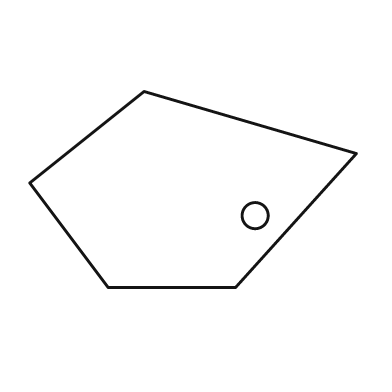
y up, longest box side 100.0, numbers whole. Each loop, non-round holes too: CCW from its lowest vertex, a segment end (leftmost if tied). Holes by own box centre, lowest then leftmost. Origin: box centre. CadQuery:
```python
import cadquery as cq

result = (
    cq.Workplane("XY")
    .moveTo(-26.0, -30.0)
    .lineTo(13.0, -30.0)
    .lineTo(50.0, 11.0)
    .lineTo(-15.0, 30.0)
    .lineTo(-50.0, 2.0)
    .close()
    .moveTo(19.0, -8.0)
    .circle(4.0)
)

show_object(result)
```